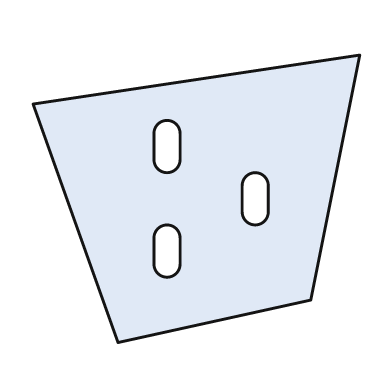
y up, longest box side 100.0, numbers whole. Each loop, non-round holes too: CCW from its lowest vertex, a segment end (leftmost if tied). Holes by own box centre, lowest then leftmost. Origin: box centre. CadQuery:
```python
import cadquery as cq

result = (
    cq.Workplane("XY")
    .moveTo(-24.0, -44.0)
    .lineTo(35.0, -31.0)
    .lineTo(50.0, 44.0)
    .lineTo(-50.0, 29.0)
    .close()
    .moveTo(-13.0, -20.0)
    .threePointArc((-9.0, -24.0), (-5.0, -20.0))
    .lineTo(-5.0, -12.0)
    .threePointArc((-9.0, -8.0), (-13.0, -12.0))
    .close()
    .moveTo(14.0, -4.0)
    .threePointArc((18.0, -8.0), (22.0, -4.0))
    .lineTo(22.0, 4.0)
    .threePointArc((18.0, 8.0), (14.0, 4.0))
    .close()
    .moveTo(-13.0, 12.0)
    .threePointArc((-9.0, 8.0), (-5.0, 12.0))
    .lineTo(-5.0, 20.0)
    .threePointArc((-9.0, 24.0), (-13.0, 20.0))
    .close()
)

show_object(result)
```